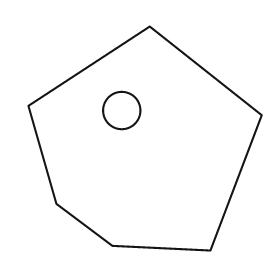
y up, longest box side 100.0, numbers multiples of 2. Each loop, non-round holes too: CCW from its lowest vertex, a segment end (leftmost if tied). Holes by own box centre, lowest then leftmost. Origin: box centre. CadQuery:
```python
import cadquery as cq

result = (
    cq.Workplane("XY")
    .moveTo(28.0, -48.0)
    .lineTo(50.0, 10.0)
    .lineTo(2.0, 48.0)
    .lineTo(-50.0, 14.0)
    .lineTo(-38.0, -28.0)
    .lineTo(-14.0, -46.0)
    .close()
    .moveTo(-10.0, 12.0)
    .circle(8.0)
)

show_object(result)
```